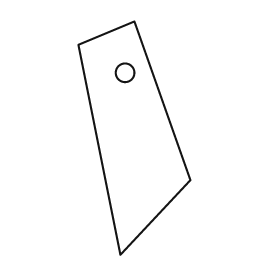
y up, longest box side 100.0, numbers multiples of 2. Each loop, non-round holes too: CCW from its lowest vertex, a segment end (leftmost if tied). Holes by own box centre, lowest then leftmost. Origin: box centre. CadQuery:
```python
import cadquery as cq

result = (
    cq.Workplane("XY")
    .moveTo(-6.0, -50.0)
    .lineTo(24.0, -18.0)
    .lineTo(0.0, 50.0)
    .lineTo(-24.0, 40.0)
    .close()
    .moveTo(-4.0, 28.0)
    .circle(4.0)
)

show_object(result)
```